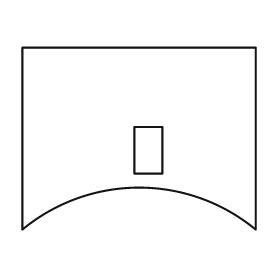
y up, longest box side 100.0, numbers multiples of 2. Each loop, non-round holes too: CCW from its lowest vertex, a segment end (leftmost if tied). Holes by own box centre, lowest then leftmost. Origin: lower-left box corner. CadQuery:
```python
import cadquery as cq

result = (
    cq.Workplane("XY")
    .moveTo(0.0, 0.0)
    .threePointArc((50.0, 18.0), (100.0, 0.0))
    .lineTo(100.0, 78.0)
    .lineTo(0.0, 78.0)
    .close()
    .moveTo(48.0, 24.0)
    .lineTo(60.0, 24.0)
    .lineTo(60.0, 44.0)
    .lineTo(48.0, 44.0)
    .close()
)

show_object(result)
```